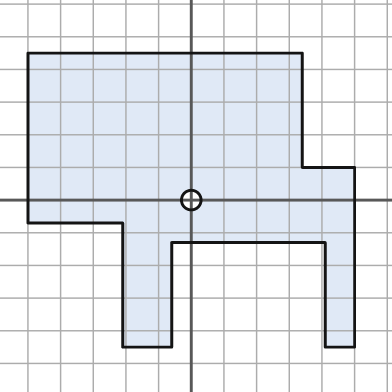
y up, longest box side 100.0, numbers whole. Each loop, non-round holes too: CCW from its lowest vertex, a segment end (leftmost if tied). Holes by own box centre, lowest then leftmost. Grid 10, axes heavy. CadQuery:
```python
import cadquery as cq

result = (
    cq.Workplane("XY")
    .moveTo(-21.0, -45.0)
    .lineTo(-6.0, -45.0)
    .lineTo(-6.0, -13.0)
    .lineTo(41.0, -13.0)
    .lineTo(41.0, -45.0)
    .lineTo(50.0, -45.0)
    .lineTo(50.0, 10.0)
    .lineTo(34.0, 10.0)
    .lineTo(34.0, 45.0)
    .lineTo(-50.0, 45.0)
    .lineTo(-50.0, -7.0)
    .lineTo(-21.0, -7.0)
    .close()
    .moveTo(0.0, 0.0)
    .circle(3.0)
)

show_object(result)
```